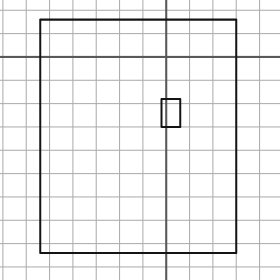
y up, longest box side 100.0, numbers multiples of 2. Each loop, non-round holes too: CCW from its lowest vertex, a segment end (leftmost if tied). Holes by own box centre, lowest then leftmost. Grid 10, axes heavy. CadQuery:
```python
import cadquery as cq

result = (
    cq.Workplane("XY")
    .moveTo(-54.0, -84.0)
    .lineTo(30.0, -84.0)
    .lineTo(30.0, 16.0)
    .lineTo(-54.0, 16.0)
    .close()
    .moveTo(-2.0, -30.0)
    .lineTo(6.0, -30.0)
    .lineTo(6.0, -18.0)
    .lineTo(-2.0, -18.0)
    .close()
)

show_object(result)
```